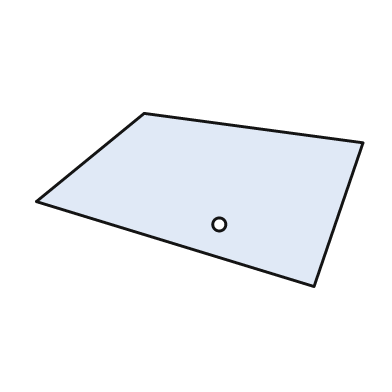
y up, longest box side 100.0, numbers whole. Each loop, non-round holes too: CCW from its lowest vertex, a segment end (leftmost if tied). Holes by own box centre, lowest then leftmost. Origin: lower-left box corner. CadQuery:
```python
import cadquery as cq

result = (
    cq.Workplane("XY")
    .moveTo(85.0, 0.0)
    .lineTo(100.0, 44.0)
    .lineTo(33.0, 53.0)
    .lineTo(0.0, 26.0)
    .close()
    .moveTo(56.0, 19.0)
    .circle(2.0)
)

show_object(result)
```